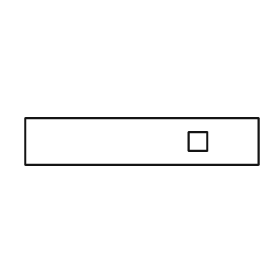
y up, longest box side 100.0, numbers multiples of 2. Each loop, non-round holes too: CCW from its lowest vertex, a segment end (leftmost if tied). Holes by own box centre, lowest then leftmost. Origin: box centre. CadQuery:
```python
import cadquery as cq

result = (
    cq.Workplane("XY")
    .moveTo(-50.0, -10.0)
    .lineTo(50.0, -10.0)
    .lineTo(50.0, 10.0)
    .lineTo(-50.0, 10.0)
    .close()
    .moveTo(20.0, -4.0)
    .lineTo(28.0, -4.0)
    .lineTo(28.0, 4.0)
    .lineTo(20.0, 4.0)
    .close()
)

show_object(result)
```